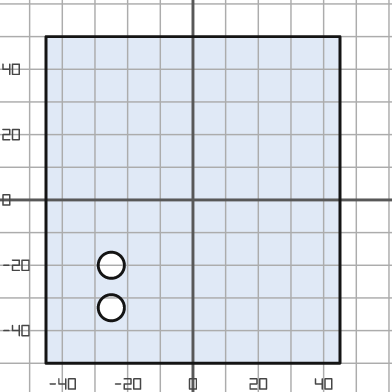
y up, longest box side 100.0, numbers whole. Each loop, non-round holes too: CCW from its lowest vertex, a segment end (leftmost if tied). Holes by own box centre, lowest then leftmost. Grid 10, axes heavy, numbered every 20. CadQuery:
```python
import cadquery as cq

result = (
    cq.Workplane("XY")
    .moveTo(-45.0, -50.0)
    .lineTo(45.0, -50.0)
    .lineTo(45.0, 50.0)
    .lineTo(-45.0, 50.0)
    .close()
    .moveTo(-25.0, -33.0)
    .circle(4.0)
    .moveTo(-25.0, -20.0)
    .circle(4.0)
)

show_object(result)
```